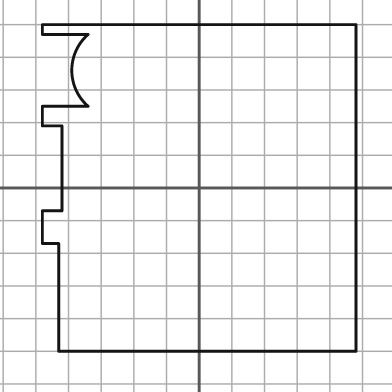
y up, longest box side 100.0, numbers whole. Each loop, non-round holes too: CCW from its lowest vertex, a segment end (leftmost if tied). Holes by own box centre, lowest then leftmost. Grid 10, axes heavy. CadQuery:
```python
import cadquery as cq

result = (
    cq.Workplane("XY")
    .moveTo(-43.0, -50.0)
    .lineTo(48.0, -50.0)
    .lineTo(48.0, 50.0)
    .lineTo(-48.0, 50.0)
    .lineTo(-48.0, 47.0)
    .lineTo(-34.0, 47.0)
    .threePointArc((-39.0, 36.0), (-34.0, 25.0))
    .lineTo(-48.0, 25.0)
    .lineTo(-48.0, 19.0)
    .lineTo(-42.0, 19.0)
    .lineTo(-42.0, -7.0)
    .lineTo(-48.0, -7.0)
    .lineTo(-48.0, -17.0)
    .lineTo(-43.0, -17.0)
    .close()
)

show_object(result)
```